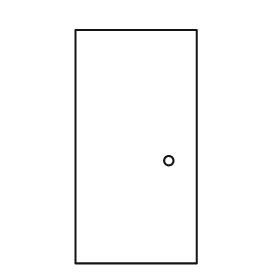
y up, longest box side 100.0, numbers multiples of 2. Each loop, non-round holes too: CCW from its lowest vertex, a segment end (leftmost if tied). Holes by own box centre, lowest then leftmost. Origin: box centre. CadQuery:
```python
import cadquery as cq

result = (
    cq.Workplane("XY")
    .moveTo(-26.0, -50.0)
    .lineTo(26.0, -50.0)
    .lineTo(26.0, 50.0)
    .lineTo(-26.0, 50.0)
    .close()
    .moveTo(14.0, -6.0)
    .circle(2.0)
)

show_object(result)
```